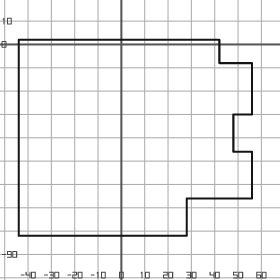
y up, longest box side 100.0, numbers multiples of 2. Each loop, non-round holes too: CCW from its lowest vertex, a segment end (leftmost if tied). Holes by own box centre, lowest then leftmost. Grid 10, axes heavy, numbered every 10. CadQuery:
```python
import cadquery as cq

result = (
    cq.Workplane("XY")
    .moveTo(-44.0, -82.0)
    .lineTo(28.0, -82.0)
    .lineTo(28.0, -66.0)
    .lineTo(56.0, -66.0)
    .lineTo(56.0, -46.0)
    .lineTo(48.0, -46.0)
    .lineTo(48.0, -30.0)
    .lineTo(56.0, -30.0)
    .lineTo(56.0, -8.0)
    .lineTo(42.0, -8.0)
    .lineTo(42.0, 2.0)
    .lineTo(-44.0, 2.0)
    .close()
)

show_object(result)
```